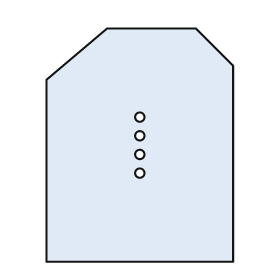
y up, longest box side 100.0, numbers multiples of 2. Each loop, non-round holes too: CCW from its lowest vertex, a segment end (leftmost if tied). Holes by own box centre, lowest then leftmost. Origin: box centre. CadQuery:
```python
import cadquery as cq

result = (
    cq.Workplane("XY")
    .moveTo(-40.0, -50.0)
    .lineTo(40.0, -50.0)
    .lineTo(40.0, 34.0)
    .lineTo(24.0, 50.0)
    .lineTo(-14.0, 50.0)
    .lineTo(-40.0, 28.0)
    .close()
    .moveTo(0.0, -12.0)
    .circle(2.0)
    .moveTo(0.0, -4.0)
    .circle(2.0)
    .moveTo(0.0, 4.0)
    .circle(2.0)
    .moveTo(0.0, 12.0)
    .circle(2.0)
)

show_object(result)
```